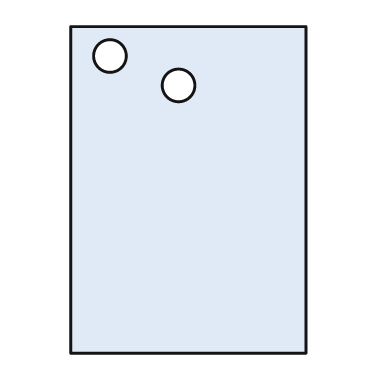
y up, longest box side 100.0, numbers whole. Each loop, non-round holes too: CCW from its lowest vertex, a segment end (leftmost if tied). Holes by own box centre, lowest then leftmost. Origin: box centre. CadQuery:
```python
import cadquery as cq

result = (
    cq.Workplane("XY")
    .moveTo(-36.0, -50.0)
    .lineTo(36.0, -50.0)
    .lineTo(36.0, 50.0)
    .lineTo(-36.0, 50.0)
    .close()
    .moveTo(-3.0, 32.0)
    .circle(5.0)
    .moveTo(-24.0, 41.0)
    .circle(5.0)
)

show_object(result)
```